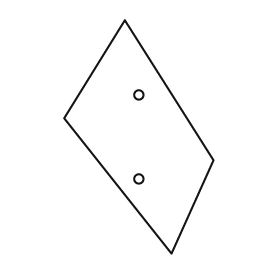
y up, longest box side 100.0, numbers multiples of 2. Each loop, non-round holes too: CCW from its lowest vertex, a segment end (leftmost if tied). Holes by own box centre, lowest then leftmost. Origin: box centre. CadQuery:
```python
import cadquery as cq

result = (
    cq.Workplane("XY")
    .moveTo(14.0, -50.0)
    .lineTo(32.0, -10.0)
    .lineTo(-6.0, 50.0)
    .lineTo(-32.0, 8.0)
    .close()
    .moveTo(0.0, -18.0)
    .circle(2.0)
    .moveTo(0.0, 18.0)
    .circle(2.0)
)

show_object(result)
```